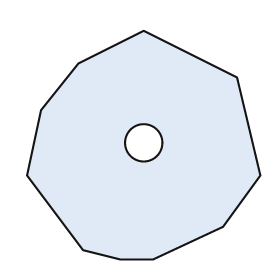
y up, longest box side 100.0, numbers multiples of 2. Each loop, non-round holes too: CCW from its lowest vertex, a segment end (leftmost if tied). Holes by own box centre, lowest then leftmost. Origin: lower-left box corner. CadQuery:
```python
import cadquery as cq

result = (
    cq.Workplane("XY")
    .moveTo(40.0, 0.0)
    .lineTo(54.0, 0.0)
    .lineTo(84.0, 14.0)
    .lineTo(100.0, 36.0)
    .lineTo(90.0, 78.0)
    .lineTo(50.0, 98.0)
    .lineTo(22.0, 84.0)
    .lineTo(6.0, 64.0)
    .lineTo(0.0, 36.0)
    .lineTo(24.0, 4.0)
    .close()
    .moveTo(50.0, 50.0)
    .circle(8.0)
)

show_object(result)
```